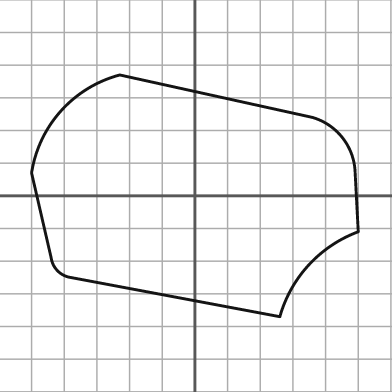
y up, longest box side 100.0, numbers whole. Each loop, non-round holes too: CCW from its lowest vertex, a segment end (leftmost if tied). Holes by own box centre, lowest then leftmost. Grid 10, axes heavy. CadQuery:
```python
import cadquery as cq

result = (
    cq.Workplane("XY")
    .moveTo(26.0, -37.0)
    .threePointArc((35.0, -21.0), (50.0, -11.0))
    .lineTo(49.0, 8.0)
    .threePointArc((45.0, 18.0), (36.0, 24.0))
    .lineTo(-23.0, 37.0)
    .threePointArc((-41.0, 26.0), (-50.0, 7.0))
    .lineTo(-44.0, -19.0)
    .threePointArc((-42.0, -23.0), (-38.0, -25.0))
    .close()
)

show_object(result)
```